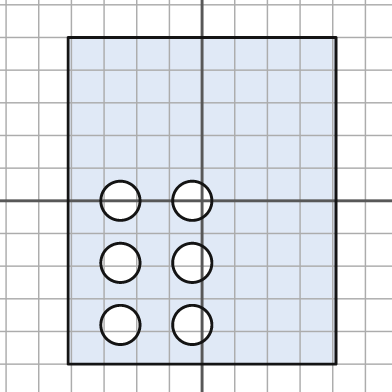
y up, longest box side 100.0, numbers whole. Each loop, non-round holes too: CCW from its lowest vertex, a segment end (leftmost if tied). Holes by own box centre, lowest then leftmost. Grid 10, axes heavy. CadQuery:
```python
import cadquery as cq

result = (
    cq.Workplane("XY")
    .moveTo(-41.0, -50.0)
    .lineTo(41.0, -50.0)
    .lineTo(41.0, 50.0)
    .lineTo(-41.0, 50.0)
    .close()
    .moveTo(-25.0, -38.0)
    .circle(6.0)
    .moveTo(-3.0, -38.0)
    .circle(6.0)
    .moveTo(-25.0, -19.0)
    .circle(6.0)
    .moveTo(-3.0, -19.0)
    .circle(6.0)
    .moveTo(-25.0, 0.0)
    .circle(6.0)
    .moveTo(-3.0, 0.0)
    .circle(6.0)
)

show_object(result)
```